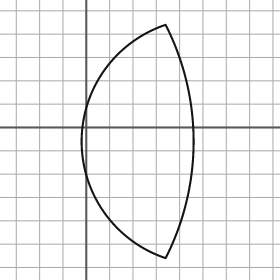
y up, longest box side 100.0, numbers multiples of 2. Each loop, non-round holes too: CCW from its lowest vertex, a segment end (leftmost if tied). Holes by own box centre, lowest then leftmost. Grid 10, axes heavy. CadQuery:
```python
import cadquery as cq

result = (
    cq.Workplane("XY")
    .moveTo(34.0, -56.0)
    .threePointArc((46.0, -6.0), (34.0, 44.0))
    .threePointArc((-2.0, -6.0), (34.0, -56.0))
    .close()
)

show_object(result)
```